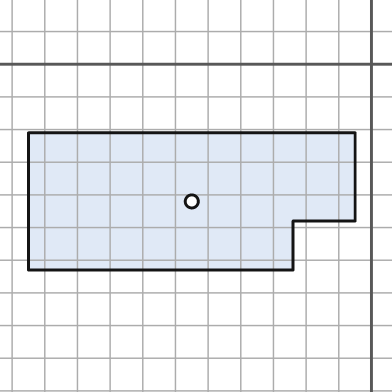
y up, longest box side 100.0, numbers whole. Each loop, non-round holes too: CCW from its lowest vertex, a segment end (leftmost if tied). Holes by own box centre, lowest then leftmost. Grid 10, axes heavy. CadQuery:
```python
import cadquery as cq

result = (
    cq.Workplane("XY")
    .moveTo(-105.0, -63.0)
    .lineTo(-24.0, -63.0)
    .lineTo(-24.0, -48.0)
    .lineTo(-5.0, -48.0)
    .lineTo(-5.0, -21.0)
    .lineTo(-105.0, -21.0)
    .close()
    .moveTo(-55.0, -42.0)
    .circle(2.0)
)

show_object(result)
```